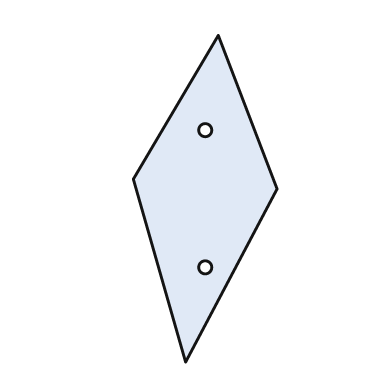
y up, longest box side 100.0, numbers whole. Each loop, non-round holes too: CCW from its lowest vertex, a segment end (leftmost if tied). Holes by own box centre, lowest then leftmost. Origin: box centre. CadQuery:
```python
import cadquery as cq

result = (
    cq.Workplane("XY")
    .moveTo(-6.0, -50.0)
    .lineTo(22.0, 3.0)
    .lineTo(4.0, 50.0)
    .lineTo(-22.0, 6.0)
    .close()
    .moveTo(0.0, -21.0)
    .circle(2.0)
    .moveTo(0.0, 21.0)
    .circle(2.0)
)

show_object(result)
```